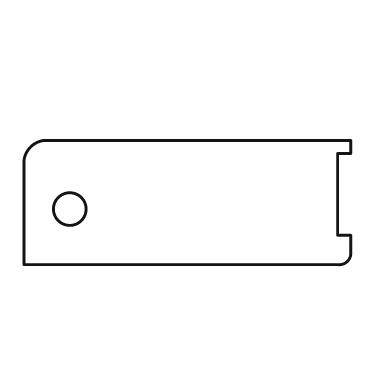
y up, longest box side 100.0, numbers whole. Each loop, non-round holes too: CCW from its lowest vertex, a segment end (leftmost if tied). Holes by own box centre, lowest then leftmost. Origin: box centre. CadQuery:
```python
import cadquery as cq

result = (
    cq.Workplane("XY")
    .moveTo(-50.0, -19.0)
    .lineTo(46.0, -19.0)
    .threePointArc((49.0, -18.0), (50.0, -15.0))
    .lineTo(50.0, -10.0)
    .lineTo(46.0, -10.0)
    .lineTo(46.0, 15.0)
    .lineTo(50.0, 15.0)
    .lineTo(50.0, 19.0)
    .lineTo(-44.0, 19.0)
    .threePointArc((-48.0, 17.0), (-50.0, 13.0))
    .close()
    .moveTo(-36.0, -2.0)
    .circle(5.0)
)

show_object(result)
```